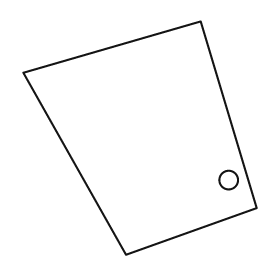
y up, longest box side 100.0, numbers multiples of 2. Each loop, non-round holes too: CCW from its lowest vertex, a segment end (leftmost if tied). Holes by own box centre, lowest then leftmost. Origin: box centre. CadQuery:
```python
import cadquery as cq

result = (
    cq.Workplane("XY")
    .moveTo(-6.0, -50.0)
    .lineTo(50.0, -30.0)
    .lineTo(26.0, 50.0)
    .lineTo(-50.0, 28.0)
    .close()
    .moveTo(38.0, -18.0)
    .circle(4.0)
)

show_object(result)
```